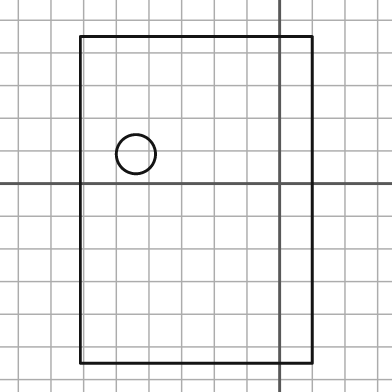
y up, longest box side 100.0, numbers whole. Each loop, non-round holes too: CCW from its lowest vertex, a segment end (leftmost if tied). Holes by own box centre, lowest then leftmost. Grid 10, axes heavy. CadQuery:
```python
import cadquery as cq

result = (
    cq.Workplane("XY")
    .moveTo(-61.0, -55.0)
    .lineTo(10.0, -55.0)
    .lineTo(10.0, 45.0)
    .lineTo(-61.0, 45.0)
    .close()
    .moveTo(-44.0, 9.0)
    .circle(6.0)
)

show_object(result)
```